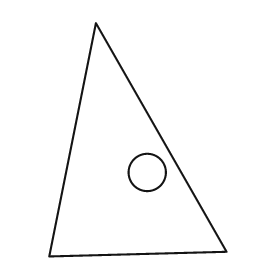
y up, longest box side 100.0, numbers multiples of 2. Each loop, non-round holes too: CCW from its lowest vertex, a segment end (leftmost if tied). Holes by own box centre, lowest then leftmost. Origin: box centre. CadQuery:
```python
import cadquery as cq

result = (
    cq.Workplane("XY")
    .moveTo(-38.0, -50.0)
    .lineTo(38.0, -48.0)
    .lineTo(-18.0, 50.0)
    .close()
    .moveTo(4.0, -14.0)
    .circle(8.0)
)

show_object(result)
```